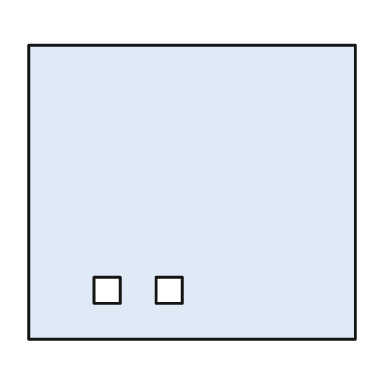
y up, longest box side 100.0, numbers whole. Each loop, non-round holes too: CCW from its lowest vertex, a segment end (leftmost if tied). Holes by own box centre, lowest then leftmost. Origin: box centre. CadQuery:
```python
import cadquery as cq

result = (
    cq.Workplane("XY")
    .moveTo(-50.0, -45.0)
    .lineTo(50.0, -45.0)
    .lineTo(50.0, 45.0)
    .lineTo(-50.0, 45.0)
    .close()
    .moveTo(-30.0, -34.0)
    .lineTo(-22.0, -34.0)
    .lineTo(-22.0, -26.0)
    .lineTo(-30.0, -26.0)
    .close()
    .moveTo(-11.0, -34.0)
    .lineTo(-3.0, -34.0)
    .lineTo(-3.0, -26.0)
    .lineTo(-11.0, -26.0)
    .close()
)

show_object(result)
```